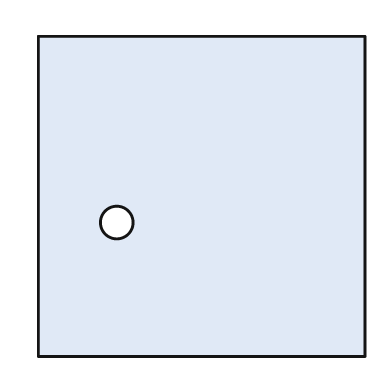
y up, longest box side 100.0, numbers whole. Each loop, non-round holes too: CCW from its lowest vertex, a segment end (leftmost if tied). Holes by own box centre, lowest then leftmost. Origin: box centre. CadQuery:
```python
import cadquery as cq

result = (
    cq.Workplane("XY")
    .moveTo(-50.0, -49.0)
    .lineTo(50.0, -49.0)
    .lineTo(50.0, 49.0)
    .lineTo(-50.0, 49.0)
    .close()
    .moveTo(-26.0, -8.0)
    .circle(5.0)
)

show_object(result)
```